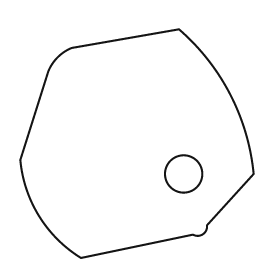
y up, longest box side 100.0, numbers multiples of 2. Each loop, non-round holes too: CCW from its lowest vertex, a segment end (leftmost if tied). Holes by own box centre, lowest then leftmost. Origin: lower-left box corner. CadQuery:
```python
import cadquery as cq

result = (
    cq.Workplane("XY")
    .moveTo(26.0, 0.0)
    .lineTo(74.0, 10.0)
    .threePointArc((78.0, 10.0), (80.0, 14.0))
    .lineTo(100.0, 36.0)
    .threePointArc((90.0, 70.0), (68.0, 98.0))
    .lineTo(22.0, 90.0)
    .threePointArc((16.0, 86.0), (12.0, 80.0))
    .lineTo(0.0, 42.0)
    .threePointArc((8.0, 18.0), (26.0, 0.0))
    .close()
    .moveTo(70.0, 36.0)
    .circle(8.0)
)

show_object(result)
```